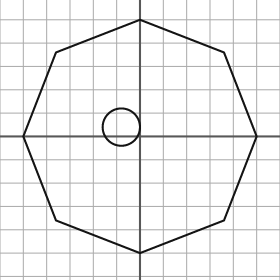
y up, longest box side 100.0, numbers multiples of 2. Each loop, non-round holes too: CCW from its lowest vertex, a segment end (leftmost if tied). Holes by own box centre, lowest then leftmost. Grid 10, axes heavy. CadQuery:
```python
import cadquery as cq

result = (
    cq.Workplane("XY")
    .moveTo(0.0, -50.0)
    .lineTo(36.0, -36.0)
    .lineTo(50.0, 0.0)
    .lineTo(36.0, 36.0)
    .lineTo(0.0, 50.0)
    .lineTo(-36.0, 36.0)
    .lineTo(-50.0, 0.0)
    .lineTo(-36.0, -36.0)
    .close()
    .moveTo(-8.0, 4.0)
    .circle(8.0)
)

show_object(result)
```